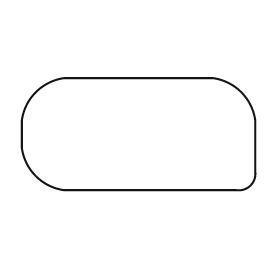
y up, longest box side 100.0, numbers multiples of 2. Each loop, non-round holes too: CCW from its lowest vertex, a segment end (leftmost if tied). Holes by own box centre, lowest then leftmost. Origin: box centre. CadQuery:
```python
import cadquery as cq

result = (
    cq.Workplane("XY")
    .moveTo(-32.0, -24.0)
    .lineTo(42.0, -24.0)
    .threePointArc((48.0, -22.0), (50.0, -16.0))
    .lineTo(50.0, 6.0)
    .threePointArc((44.0, 18.0), (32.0, 24.0))
    .lineTo(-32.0, 24.0)
    .threePointArc((-44.0, 18.0), (-50.0, 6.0))
    .lineTo(-50.0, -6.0)
    .threePointArc((-44.0, -18.0), (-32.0, -24.0))
    .close()
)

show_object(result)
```